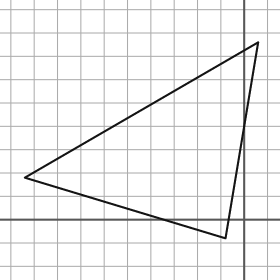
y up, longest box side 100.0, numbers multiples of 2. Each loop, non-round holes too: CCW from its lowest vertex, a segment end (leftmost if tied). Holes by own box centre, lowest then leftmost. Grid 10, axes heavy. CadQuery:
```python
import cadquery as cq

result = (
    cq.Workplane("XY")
    .moveTo(-8.0, -8.0)
    .lineTo(6.0, 76.0)
    .lineTo(-94.0, 18.0)
    .close()
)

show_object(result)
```